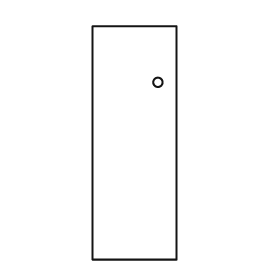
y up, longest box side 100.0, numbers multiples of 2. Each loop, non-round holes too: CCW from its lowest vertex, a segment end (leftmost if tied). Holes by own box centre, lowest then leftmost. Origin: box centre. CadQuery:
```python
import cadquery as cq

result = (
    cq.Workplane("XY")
    .moveTo(-18.0, -50.0)
    .lineTo(18.0, -50.0)
    .lineTo(18.0, 50.0)
    .lineTo(-18.0, 50.0)
    .close()
    .moveTo(10.0, 26.0)
    .circle(2.0)
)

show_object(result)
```